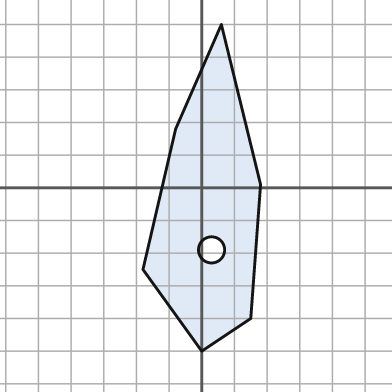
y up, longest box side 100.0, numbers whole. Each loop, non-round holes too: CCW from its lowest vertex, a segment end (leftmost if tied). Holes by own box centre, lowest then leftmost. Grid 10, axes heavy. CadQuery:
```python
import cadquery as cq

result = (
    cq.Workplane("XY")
    .moveTo(0.0, -50.0)
    .lineTo(15.0, -40.0)
    .lineTo(18.0, 1.0)
    .lineTo(6.0, 50.0)
    .lineTo(-8.0, 18.0)
    .lineTo(-18.0, -25.0)
    .close()
    .moveTo(3.0, -19.0)
    .circle(4.0)
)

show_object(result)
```